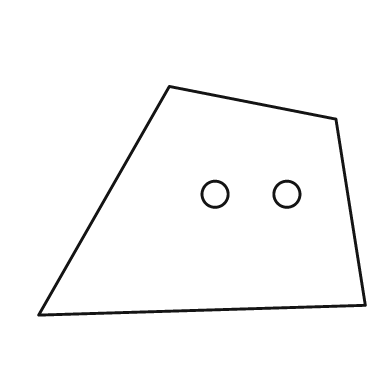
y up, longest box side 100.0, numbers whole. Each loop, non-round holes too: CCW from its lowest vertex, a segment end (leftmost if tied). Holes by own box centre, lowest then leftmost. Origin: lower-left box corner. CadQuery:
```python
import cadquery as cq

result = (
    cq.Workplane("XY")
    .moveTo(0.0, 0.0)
    .lineTo(100.0, 3.0)
    .lineTo(91.0, 60.0)
    .lineTo(40.0, 70.0)
    .close()
    .moveTo(54.0, 37.0)
    .circle(4.0)
    .moveTo(76.0, 37.0)
    .circle(4.0)
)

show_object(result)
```